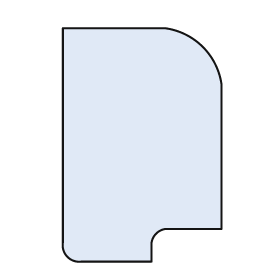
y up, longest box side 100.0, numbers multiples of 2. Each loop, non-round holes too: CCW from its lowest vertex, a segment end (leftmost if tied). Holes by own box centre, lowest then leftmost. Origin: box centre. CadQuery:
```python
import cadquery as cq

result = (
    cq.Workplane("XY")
    .moveTo(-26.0, -50.0)
    .lineTo(4.0, -50.0)
    .lineTo(4.0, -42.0)
    .threePointArc((6.0, -38.0), (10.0, -36.0))
    .lineTo(34.0, -36.0)
    .lineTo(34.0, 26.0)
    .threePointArc((26.0, 42.0), (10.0, 50.0))
    .lineTo(-34.0, 50.0)
    .lineTo(-34.0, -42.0)
    .threePointArc((-32.0, -48.0), (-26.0, -50.0))
    .close()
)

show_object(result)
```